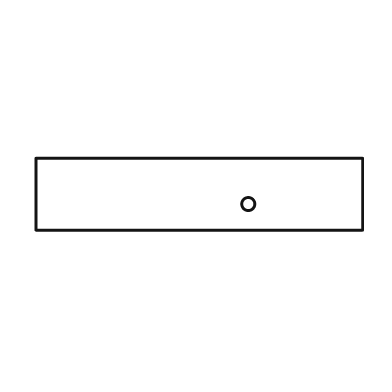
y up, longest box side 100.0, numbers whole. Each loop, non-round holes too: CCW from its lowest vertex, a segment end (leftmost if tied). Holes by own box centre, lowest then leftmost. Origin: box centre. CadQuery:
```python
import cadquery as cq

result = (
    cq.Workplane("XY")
    .moveTo(-50.0, -11.0)
    .lineTo(50.0, -11.0)
    .lineTo(50.0, 11.0)
    .lineTo(-50.0, 11.0)
    .close()
    .moveTo(15.0, -3.0)
    .circle(2.0)
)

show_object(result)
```